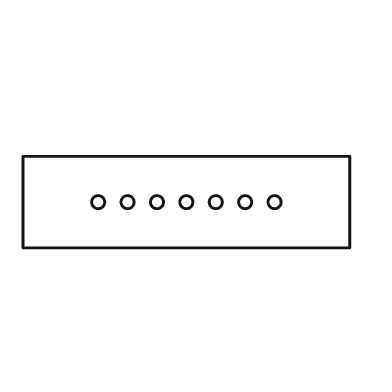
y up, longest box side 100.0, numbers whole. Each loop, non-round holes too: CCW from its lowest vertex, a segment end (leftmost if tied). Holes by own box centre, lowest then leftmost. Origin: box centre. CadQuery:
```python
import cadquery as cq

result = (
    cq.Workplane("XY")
    .moveTo(-50.0, -14.0)
    .lineTo(50.0, -14.0)
    .lineTo(50.0, 14.0)
    .lineTo(-50.0, 14.0)
    .close()
    .moveTo(-27.0, 0.0)
    .circle(2.0)
    .moveTo(-18.0, 0.0)
    .circle(2.0)
    .moveTo(-9.0, 0.0)
    .circle(2.0)
    .moveTo(0.0, 0.0)
    .circle(2.0)
    .moveTo(9.0, 0.0)
    .circle(2.0)
    .moveTo(18.0, 0.0)
    .circle(2.0)
    .moveTo(27.0, 0.0)
    .circle(2.0)
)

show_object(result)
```